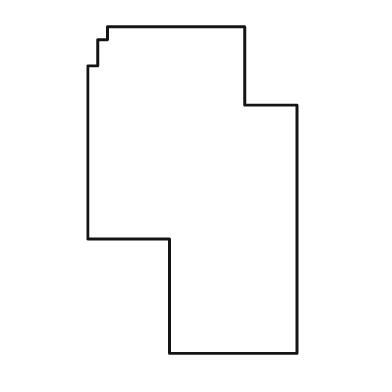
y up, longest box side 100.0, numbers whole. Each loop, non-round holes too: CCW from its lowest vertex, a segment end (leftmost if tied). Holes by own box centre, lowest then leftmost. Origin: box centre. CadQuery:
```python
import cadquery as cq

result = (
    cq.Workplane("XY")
    .moveTo(-7.0, -50.0)
    .lineTo(32.0, -50.0)
    .lineTo(32.0, 26.0)
    .lineTo(16.0, 26.0)
    .lineTo(16.0, 50.0)
    .lineTo(-26.0, 50.0)
    .lineTo(-26.0, 46.0)
    .lineTo(-29.0, 46.0)
    .lineTo(-29.0, 38.0)
    .lineTo(-32.0, 38.0)
    .lineTo(-32.0, -15.0)
    .lineTo(-7.0, -15.0)
    .close()
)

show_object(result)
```